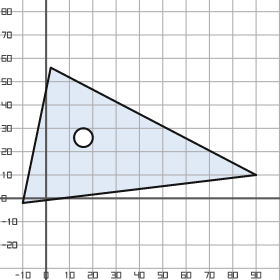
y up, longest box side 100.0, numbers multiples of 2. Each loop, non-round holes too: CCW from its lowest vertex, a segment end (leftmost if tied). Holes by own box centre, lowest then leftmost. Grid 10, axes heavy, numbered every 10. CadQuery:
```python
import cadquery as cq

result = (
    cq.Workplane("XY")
    .moveTo(-10.0, -2.0)
    .lineTo(90.0, 10.0)
    .lineTo(2.0, 56.0)
    .close()
    .moveTo(16.0, 26.0)
    .circle(4.0)
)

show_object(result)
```